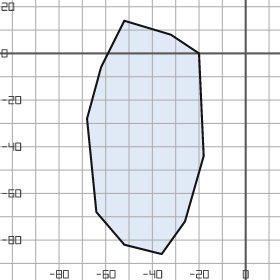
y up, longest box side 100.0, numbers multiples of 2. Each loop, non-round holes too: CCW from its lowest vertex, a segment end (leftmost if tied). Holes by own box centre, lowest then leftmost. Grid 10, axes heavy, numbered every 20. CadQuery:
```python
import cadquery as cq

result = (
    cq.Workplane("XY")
    .moveTo(-36.0, -86.0)
    .lineTo(-26.0, -72.0)
    .lineTo(-18.0, -44.0)
    .lineTo(-20.0, 0.0)
    .lineTo(-32.0, 8.0)
    .lineTo(-52.0, 14.0)
    .lineTo(-62.0, -6.0)
    .lineTo(-68.0, -28.0)
    .lineTo(-64.0, -68.0)
    .lineTo(-52.0, -82.0)
    .close()
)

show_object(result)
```